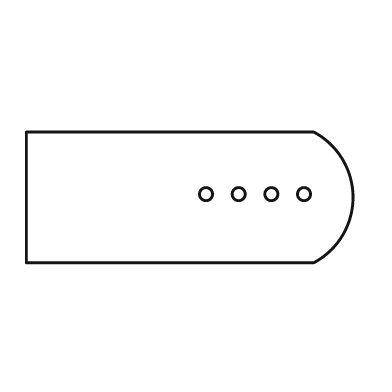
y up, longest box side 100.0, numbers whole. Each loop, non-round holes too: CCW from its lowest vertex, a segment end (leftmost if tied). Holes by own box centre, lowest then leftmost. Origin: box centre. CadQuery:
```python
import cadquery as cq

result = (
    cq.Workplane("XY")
    .moveTo(-50.0, -20.0)
    .lineTo(38.0, -20.0)
    .threePointArc((50.0, 0.0), (38.0, 20.0))
    .lineTo(-50.0, 20.0)
    .close()
    .moveTo(5.0, 1.0)
    .circle(2.0)
    .moveTo(15.0, 1.0)
    .circle(2.0)
    .moveTo(25.0, 1.0)
    .circle(2.0)
    .moveTo(35.0, 1.0)
    .circle(2.0)
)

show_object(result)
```